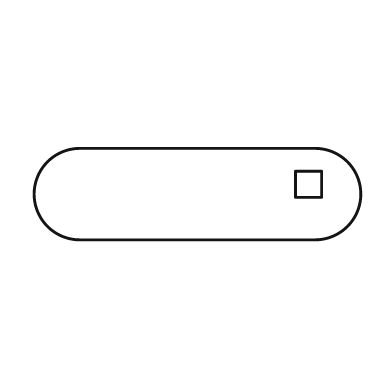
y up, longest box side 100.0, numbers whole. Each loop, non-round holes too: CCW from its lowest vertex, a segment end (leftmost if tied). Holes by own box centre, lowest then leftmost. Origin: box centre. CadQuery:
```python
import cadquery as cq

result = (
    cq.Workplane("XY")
    .moveTo(-36.0, -14.0)
    .lineTo(36.0, -14.0)
    .threePointArc((50.0, 0.0), (36.0, 14.0))
    .lineTo(-36.0, 14.0)
    .threePointArc((-50.0, 0.0), (-36.0, -14.0))
    .close()
    .moveTo(30.0, -1.0)
    .lineTo(38.0, -1.0)
    .lineTo(38.0, 7.0)
    .lineTo(30.0, 7.0)
    .close()
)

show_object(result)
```